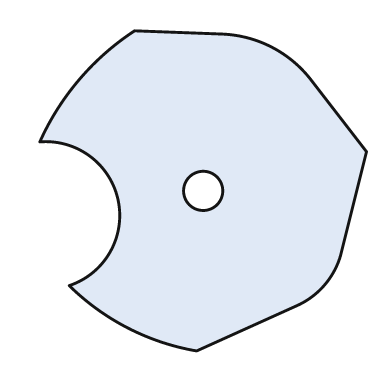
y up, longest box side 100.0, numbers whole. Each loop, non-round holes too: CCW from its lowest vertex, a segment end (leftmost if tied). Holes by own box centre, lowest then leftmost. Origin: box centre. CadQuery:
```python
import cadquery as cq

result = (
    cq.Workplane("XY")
    .moveTo(-2.0, -49.0)
    .lineTo(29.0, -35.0)
    .threePointArc((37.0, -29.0), (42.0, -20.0))
    .lineTo(50.0, 12.0)
    .lineTo(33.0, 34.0)
    .threePointArc((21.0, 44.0), (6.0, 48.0))
    .lineTo(-21.0, 49.0)
    .threePointArc((-38.0, 34.0), (-50.0, 15.0))
    .threePointArc((-26.0, -3.0), (-41.0, -29.0))
    .threePointArc((-23.0, -42.0), (-2.0, -49.0))
    .close()
    .moveTo(0.0, 0.0)
    .circle(6.0)
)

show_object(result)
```